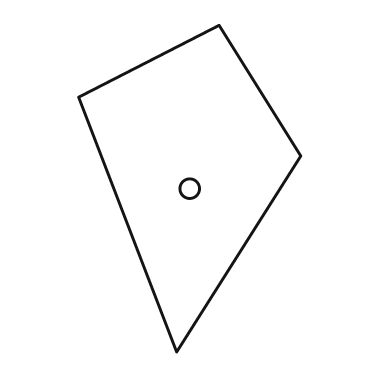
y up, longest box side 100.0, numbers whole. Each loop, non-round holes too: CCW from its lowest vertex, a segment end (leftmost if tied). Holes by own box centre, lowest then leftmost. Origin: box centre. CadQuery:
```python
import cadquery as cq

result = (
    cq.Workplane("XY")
    .moveTo(-4.0, -50.0)
    .lineTo(34.0, 10.0)
    .lineTo(9.0, 50.0)
    .lineTo(-34.0, 28.0)
    .close()
    .moveTo(0.0, 0.0)
    .circle(3.0)
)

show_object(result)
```